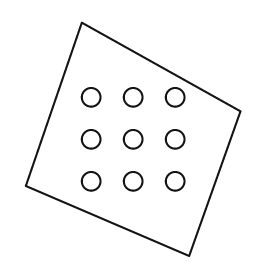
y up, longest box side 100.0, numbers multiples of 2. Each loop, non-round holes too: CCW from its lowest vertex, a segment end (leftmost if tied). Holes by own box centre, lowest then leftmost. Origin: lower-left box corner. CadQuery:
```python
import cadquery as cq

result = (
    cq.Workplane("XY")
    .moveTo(70.0, 0.0)
    .lineTo(92.0, 62.0)
    .lineTo(24.0, 100.0)
    .lineTo(0.0, 30.0)
    .close()
    .moveTo(28.0, 32.0)
    .circle(4.0)
    .moveTo(46.0, 32.0)
    .circle(4.0)
    .moveTo(64.0, 32.0)
    .circle(4.0)
    .moveTo(28.0, 50.0)
    .circle(4.0)
    .moveTo(46.0, 50.0)
    .circle(4.0)
    .moveTo(64.0, 50.0)
    .circle(4.0)
    .moveTo(28.0, 68.0)
    .circle(4.0)
    .moveTo(46.0, 68.0)
    .circle(4.0)
    .moveTo(64.0, 68.0)
    .circle(4.0)
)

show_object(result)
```